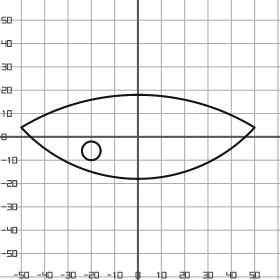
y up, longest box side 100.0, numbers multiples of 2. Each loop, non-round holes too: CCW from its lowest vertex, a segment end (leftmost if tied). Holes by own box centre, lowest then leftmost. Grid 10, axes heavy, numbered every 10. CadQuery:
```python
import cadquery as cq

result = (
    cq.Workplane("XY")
    .moveTo(-50.0, 4.0)
    .threePointArc((0.0, -18.0), (50.0, 4.0))
    .threePointArc((0.0, 18.0), (-50.0, 4.0))
    .close()
    .moveTo(-20.0, -6.0)
    .circle(4.0)
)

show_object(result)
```